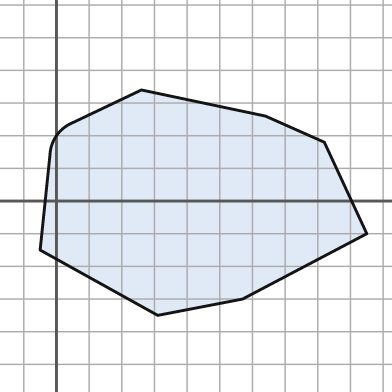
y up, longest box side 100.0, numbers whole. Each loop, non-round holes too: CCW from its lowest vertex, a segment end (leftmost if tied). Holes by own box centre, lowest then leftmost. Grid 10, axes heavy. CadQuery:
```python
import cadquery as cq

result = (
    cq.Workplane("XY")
    .moveTo(31.0, -35.0)
    .lineTo(57.0, -30.0)
    .lineTo(95.0, -10.0)
    .lineTo(82.0, 18.0)
    .lineTo(64.0, 26.0)
    .lineTo(26.0, 34.0)
    .lineTo(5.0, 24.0)
    .threePointArc((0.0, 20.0), (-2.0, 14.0))
    .lineTo(-5.0, -15.0)
    .close()
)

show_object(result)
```